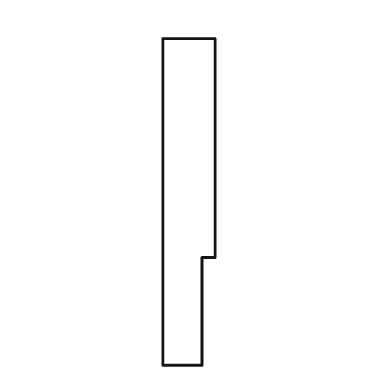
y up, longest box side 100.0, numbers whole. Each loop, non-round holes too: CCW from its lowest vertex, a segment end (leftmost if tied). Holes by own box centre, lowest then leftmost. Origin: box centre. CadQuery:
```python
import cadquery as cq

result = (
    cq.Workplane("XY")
    .moveTo(-8.0, -50.0)
    .lineTo(4.0, -50.0)
    .lineTo(4.0, -17.0)
    .lineTo(8.0, -17.0)
    .lineTo(8.0, 50.0)
    .lineTo(-8.0, 50.0)
    .close()
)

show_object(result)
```